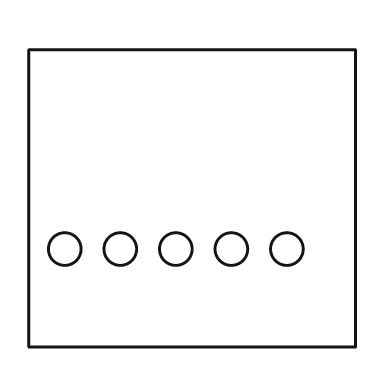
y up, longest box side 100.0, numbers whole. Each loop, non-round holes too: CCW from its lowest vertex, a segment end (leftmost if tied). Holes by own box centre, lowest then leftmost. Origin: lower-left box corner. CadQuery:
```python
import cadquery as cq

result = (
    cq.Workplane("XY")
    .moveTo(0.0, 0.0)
    .lineTo(100.0, 0.0)
    .lineTo(100.0, 91.0)
    .lineTo(0.0, 91.0)
    .close()
    .moveTo(11.0, 30.0)
    .circle(5.0)
    .moveTo(28.0, 30.0)
    .circle(5.0)
    .moveTo(45.0, 30.0)
    .circle(5.0)
    .moveTo(62.0, 30.0)
    .circle(5.0)
    .moveTo(79.0, 30.0)
    .circle(5.0)
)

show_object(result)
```